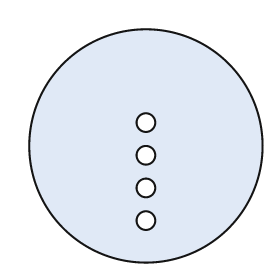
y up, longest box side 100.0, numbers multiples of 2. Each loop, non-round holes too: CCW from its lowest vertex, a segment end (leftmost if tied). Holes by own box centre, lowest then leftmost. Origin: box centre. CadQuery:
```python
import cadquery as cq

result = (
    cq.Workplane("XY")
    .moveTo(0.0, 0.0)
    .circle(50.0)
    .moveTo(0.0, -32.0)
    .circle(4.0)
    .moveTo(0.0, -18.0)
    .circle(4.0)
    .moveTo(0.0, -4.0)
    .circle(4.0)
    .moveTo(0.0, 10.0)
    .circle(4.0)
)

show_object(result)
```